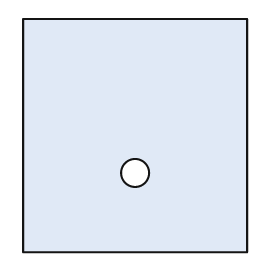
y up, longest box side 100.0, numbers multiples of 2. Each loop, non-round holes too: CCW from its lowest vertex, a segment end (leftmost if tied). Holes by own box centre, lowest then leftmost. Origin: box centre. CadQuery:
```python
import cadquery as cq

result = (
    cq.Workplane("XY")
    .moveTo(-48.0, -50.0)
    .lineTo(48.0, -50.0)
    .lineTo(48.0, 50.0)
    .lineTo(-48.0, 50.0)
    .close()
    .moveTo(0.0, -16.0)
    .circle(6.0)
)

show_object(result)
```